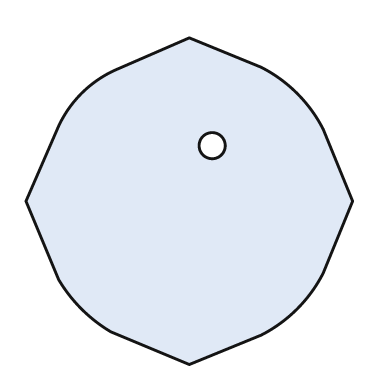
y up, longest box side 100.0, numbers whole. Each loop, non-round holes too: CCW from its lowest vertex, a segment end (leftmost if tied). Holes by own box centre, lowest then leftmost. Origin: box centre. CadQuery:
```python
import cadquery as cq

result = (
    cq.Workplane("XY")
    .moveTo(0.0, -50.0)
    .lineTo(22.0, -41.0)
    .threePointArc((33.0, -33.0), (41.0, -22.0))
    .lineTo(50.0, 0.0)
    .lineTo(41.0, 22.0)
    .threePointArc((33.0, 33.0), (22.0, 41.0))
    .lineTo(0.0, 50.0)
    .lineTo(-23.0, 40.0)
    .threePointArc((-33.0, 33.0), (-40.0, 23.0))
    .lineTo(-50.0, 0.0)
    .lineTo(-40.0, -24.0)
    .threePointArc((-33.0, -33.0), (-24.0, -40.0))
    .close()
    .moveTo(7.0, 17.0)
    .circle(4.0)
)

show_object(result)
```